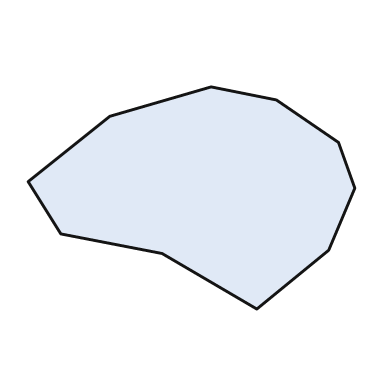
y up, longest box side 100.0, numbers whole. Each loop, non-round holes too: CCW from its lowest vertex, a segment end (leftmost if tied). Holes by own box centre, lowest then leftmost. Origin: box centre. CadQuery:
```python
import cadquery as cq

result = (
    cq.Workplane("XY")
    .moveTo(20.0, -34.0)
    .lineTo(42.0, -16.0)
    .lineTo(50.0, 3.0)
    .lineTo(45.0, 17.0)
    .lineTo(26.0, 30.0)
    .lineTo(6.0, 34.0)
    .lineTo(-25.0, 25.0)
    .lineTo(-50.0, 5.0)
    .lineTo(-40.0, -11.0)
    .lineTo(-9.0, -17.0)
    .close()
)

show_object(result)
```